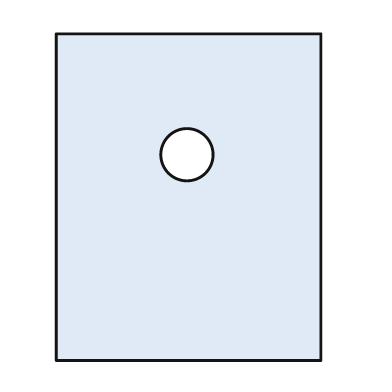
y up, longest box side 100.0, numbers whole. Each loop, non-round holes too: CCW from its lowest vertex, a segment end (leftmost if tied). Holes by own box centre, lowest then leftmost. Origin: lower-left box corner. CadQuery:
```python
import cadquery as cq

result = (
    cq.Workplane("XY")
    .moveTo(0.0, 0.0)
    .lineTo(81.0, 0.0)
    .lineTo(81.0, 100.0)
    .lineTo(0.0, 100.0)
    .close()
    .moveTo(40.0, 63.0)
    .circle(8.0)
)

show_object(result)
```